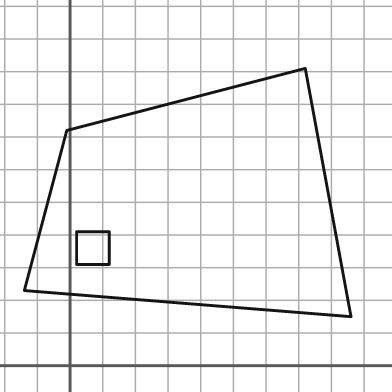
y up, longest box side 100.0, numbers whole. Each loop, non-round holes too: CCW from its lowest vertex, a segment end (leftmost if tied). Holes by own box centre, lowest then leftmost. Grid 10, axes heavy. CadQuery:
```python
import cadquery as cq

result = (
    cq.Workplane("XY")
    .moveTo(86.0, 15.0)
    .lineTo(72.0, 91.0)
    .lineTo(-1.0, 72.0)
    .lineTo(-14.0, 23.0)
    .close()
    .moveTo(2.0, 31.0)
    .lineTo(12.0, 31.0)
    .lineTo(12.0, 41.0)
    .lineTo(2.0, 41.0)
    .close()
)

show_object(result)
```